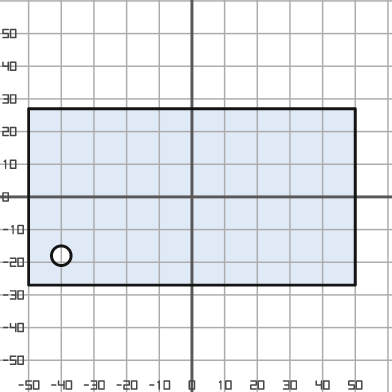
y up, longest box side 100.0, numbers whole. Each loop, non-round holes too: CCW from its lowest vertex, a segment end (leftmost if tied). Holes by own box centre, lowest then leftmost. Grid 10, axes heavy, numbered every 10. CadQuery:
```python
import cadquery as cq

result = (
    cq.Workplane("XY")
    .moveTo(-50.0, -27.0)
    .lineTo(50.0, -27.0)
    .lineTo(50.0, 27.0)
    .lineTo(-50.0, 27.0)
    .close()
    .moveTo(-40.0, -18.0)
    .circle(3.0)
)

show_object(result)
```